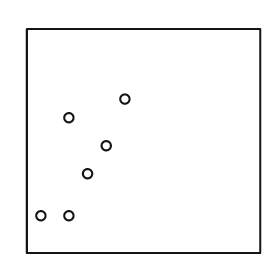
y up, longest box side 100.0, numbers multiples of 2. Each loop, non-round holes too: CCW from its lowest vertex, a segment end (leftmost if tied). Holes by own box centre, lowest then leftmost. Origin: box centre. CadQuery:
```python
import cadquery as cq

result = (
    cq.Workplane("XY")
    .moveTo(-50.0, -48.0)
    .lineTo(50.0, -48.0)
    .lineTo(50.0, 48.0)
    .lineTo(-50.0, 48.0)
    .close()
    .moveTo(-44.0, -32.0)
    .circle(2.0)
    .moveTo(-32.0, -32.0)
    .circle(2.0)
    .moveTo(-24.0, -14.0)
    .circle(2.0)
    .moveTo(-16.0, -2.0)
    .circle(2.0)
    .moveTo(-32.0, 10.0)
    .circle(2.0)
    .moveTo(-8.0, 18.0)
    .circle(2.0)
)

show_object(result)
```